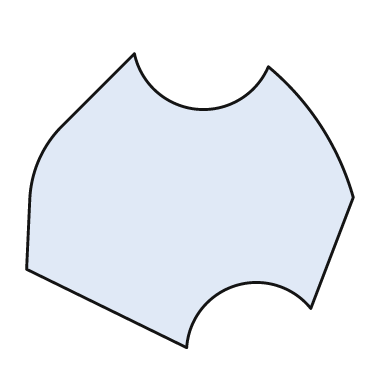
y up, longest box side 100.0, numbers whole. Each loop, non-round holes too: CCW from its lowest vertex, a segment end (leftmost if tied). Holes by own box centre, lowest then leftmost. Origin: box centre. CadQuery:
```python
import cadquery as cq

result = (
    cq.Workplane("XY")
    .moveTo(-1.0, -45.0)
    .threePointArc((14.0, -26.0), (37.0, -33.0))
    .lineTo(50.0, 1.0)
    .threePointArc((40.0, 23.0), (24.0, 41.0))
    .threePointArc((2.0, 28.0), (-17.0, 45.0))
    .lineTo(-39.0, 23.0)
    .threePointArc((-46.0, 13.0), (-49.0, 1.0))
    .lineTo(-50.0, -21.0)
    .close()
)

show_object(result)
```